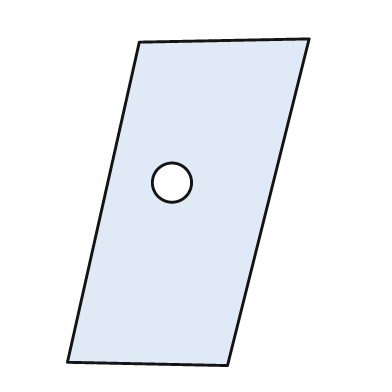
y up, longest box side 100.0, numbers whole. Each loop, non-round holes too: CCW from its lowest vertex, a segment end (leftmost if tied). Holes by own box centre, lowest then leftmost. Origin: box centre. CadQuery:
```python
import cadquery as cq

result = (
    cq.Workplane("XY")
    .moveTo(12.0, -50.0)
    .lineTo(37.0, 50.0)
    .lineTo(-15.0, 49.0)
    .lineTo(-37.0, -49.0)
    .close()
    .moveTo(-5.0, 6.0)
    .circle(6.0)
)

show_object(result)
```